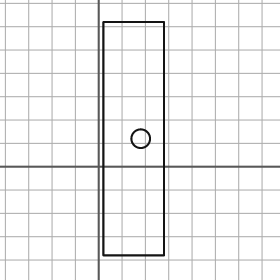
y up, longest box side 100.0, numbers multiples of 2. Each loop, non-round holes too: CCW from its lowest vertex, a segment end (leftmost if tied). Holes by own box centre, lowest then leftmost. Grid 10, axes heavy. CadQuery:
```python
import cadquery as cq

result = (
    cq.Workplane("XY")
    .moveTo(2.0, -38.0)
    .lineTo(28.0, -38.0)
    .lineTo(28.0, 62.0)
    .lineTo(2.0, 62.0)
    .close()
    .moveTo(18.0, 12.0)
    .circle(4.0)
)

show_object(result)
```